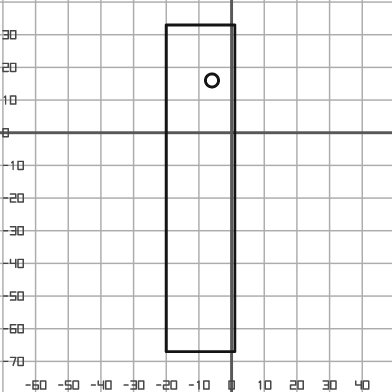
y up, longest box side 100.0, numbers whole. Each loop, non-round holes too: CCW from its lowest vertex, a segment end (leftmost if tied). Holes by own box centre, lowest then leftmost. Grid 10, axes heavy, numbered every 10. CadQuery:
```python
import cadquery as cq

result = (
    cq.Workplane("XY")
    .moveTo(-20.0, -67.0)
    .lineTo(1.0, -67.0)
    .lineTo(1.0, 33.0)
    .lineTo(-20.0, 33.0)
    .close()
    .moveTo(-6.0, 16.0)
    .circle(2.0)
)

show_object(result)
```